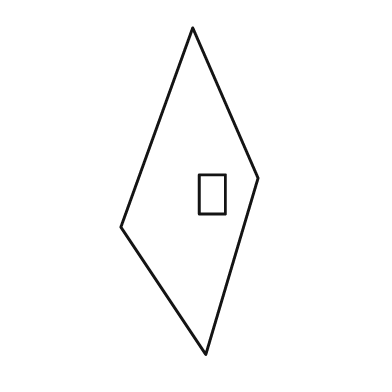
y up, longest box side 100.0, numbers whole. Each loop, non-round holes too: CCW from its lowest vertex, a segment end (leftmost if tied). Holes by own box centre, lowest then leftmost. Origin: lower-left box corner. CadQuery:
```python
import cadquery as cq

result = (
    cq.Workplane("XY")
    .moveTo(26.0, 0.0)
    .lineTo(42.0, 54.0)
    .lineTo(22.0, 100.0)
    .lineTo(0.0, 39.0)
    .close()
    .moveTo(24.0, 43.0)
    .lineTo(32.0, 43.0)
    .lineTo(32.0, 55.0)
    .lineTo(24.0, 55.0)
    .close()
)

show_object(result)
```